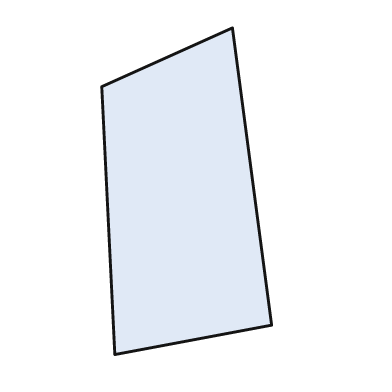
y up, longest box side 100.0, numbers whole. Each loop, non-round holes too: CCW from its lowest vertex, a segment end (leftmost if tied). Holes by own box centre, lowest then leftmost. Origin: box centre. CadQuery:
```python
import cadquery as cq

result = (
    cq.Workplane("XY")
    .moveTo(-22.0, -50.0)
    .lineTo(26.0, -41.0)
    .lineTo(14.0, 50.0)
    .lineTo(-26.0, 32.0)
    .close()
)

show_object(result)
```